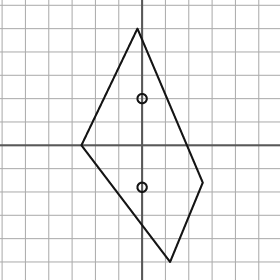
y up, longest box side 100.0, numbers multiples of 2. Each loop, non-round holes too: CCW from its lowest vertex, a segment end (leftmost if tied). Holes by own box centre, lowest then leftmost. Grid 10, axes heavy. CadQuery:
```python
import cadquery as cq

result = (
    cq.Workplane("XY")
    .moveTo(12.0, -50.0)
    .lineTo(26.0, -16.0)
    .lineTo(-2.0, 50.0)
    .lineTo(-26.0, 0.0)
    .close()
    .moveTo(0.0, -18.0)
    .circle(2.0)
    .moveTo(0.0, 20.0)
    .circle(2.0)
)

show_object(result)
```